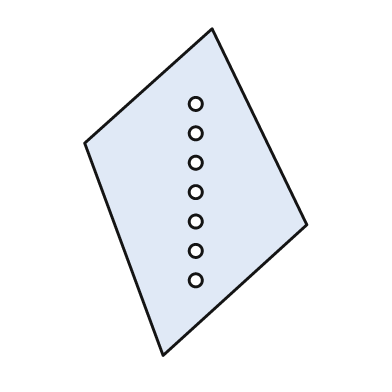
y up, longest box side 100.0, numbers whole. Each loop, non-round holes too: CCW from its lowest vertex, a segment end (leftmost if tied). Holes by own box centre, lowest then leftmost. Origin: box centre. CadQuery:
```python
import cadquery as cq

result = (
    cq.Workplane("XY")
    .moveTo(-10.0, -50.0)
    .lineTo(34.0, -10.0)
    .lineTo(5.0, 50.0)
    .lineTo(-34.0, 15.0)
    .close()
    .moveTo(0.0, -27.0)
    .circle(2.0)
    .moveTo(0.0, -18.0)
    .circle(2.0)
    .moveTo(0.0, -9.0)
    .circle(2.0)
    .moveTo(0.0, 0.0)
    .circle(2.0)
    .moveTo(0.0, 9.0)
    .circle(2.0)
    .moveTo(0.0, 18.0)
    .circle(2.0)
    .moveTo(0.0, 27.0)
    .circle(2.0)
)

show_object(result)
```